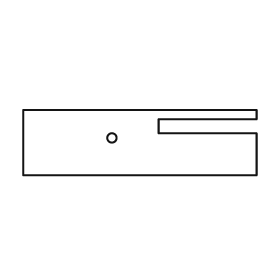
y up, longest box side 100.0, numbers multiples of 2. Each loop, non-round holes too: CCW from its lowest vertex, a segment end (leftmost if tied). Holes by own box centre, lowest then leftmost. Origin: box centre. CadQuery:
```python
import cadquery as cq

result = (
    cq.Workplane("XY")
    .moveTo(-50.0, -14.0)
    .lineTo(50.0, -14.0)
    .lineTo(50.0, 4.0)
    .lineTo(8.0, 4.0)
    .lineTo(8.0, 10.0)
    .lineTo(50.0, 10.0)
    .lineTo(50.0, 14.0)
    .lineTo(-50.0, 14.0)
    .close()
    .moveTo(-12.0, 2.0)
    .circle(2.0)
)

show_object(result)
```